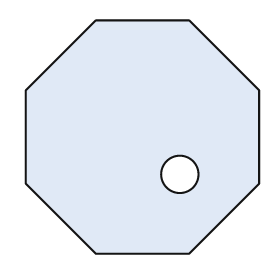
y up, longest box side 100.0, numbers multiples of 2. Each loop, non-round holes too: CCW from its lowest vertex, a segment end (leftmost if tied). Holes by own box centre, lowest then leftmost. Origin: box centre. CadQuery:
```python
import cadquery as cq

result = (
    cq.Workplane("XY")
    .moveTo(-20.0, -50.0)
    .lineTo(20.0, -50.0)
    .lineTo(50.0, -20.0)
    .lineTo(50.0, 20.0)
    .lineTo(20.0, 50.0)
    .lineTo(-20.0, 50.0)
    .lineTo(-50.0, 20.0)
    .lineTo(-50.0, -20.0)
    .close()
    .moveTo(16.0, -16.0)
    .circle(8.0)
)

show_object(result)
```